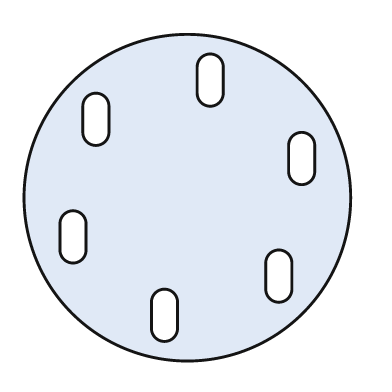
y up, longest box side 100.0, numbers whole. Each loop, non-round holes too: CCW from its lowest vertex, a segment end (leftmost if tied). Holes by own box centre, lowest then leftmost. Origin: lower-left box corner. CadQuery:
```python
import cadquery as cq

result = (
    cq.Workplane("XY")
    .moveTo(50.0, 50.0)
    .circle(50.0)
    .moveTo(39.0, 10.0)
    .threePointArc((43.0, 6.0), (47.0, 10.0))
    .lineTo(47.0, 18.0)
    .threePointArc((43.0, 22.0), (39.0, 18.0))
    .close()
    .moveTo(74.0, 22.0)
    .threePointArc((78.0, 18.0), (82.0, 22.0))
    .lineTo(82.0, 30.0)
    .threePointArc((78.0, 34.0), (74.0, 30.0))
    .close()
    .moveTo(11.0, 34.0)
    .threePointArc((15.0, 30.0), (19.0, 34.0))
    .lineTo(19.0, 42.0)
    .threePointArc((15.0, 46.0), (11.0, 42.0))
    .close()
    .moveTo(81.0, 58.0)
    .threePointArc((85.0, 54.0), (89.0, 58.0))
    .lineTo(89.0, 66.0)
    .threePointArc((85.0, 70.0), (81.0, 66.0))
    .close()
    .moveTo(18.0, 70.0)
    .threePointArc((22.0, 66.0), (26.0, 70.0))
    .lineTo(26.0, 78.0)
    .threePointArc((22.0, 82.0), (18.0, 78.0))
    .close()
    .moveTo(53.0, 82.0)
    .threePointArc((57.0, 78.0), (61.0, 82.0))
    .lineTo(61.0, 90.0)
    .threePointArc((57.0, 94.0), (53.0, 90.0))
    .close()
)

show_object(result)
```